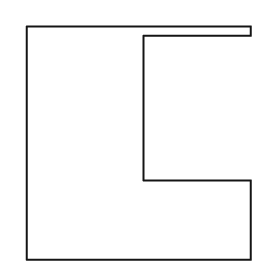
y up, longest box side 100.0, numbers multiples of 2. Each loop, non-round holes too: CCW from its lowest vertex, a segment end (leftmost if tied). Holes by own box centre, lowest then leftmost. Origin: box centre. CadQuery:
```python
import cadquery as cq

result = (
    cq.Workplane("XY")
    .moveTo(-48.0, -50.0)
    .lineTo(48.0, -50.0)
    .lineTo(48.0, -16.0)
    .lineTo(2.0, -16.0)
    .lineTo(2.0, 46.0)
    .lineTo(48.0, 46.0)
    .lineTo(48.0, 50.0)
    .lineTo(-48.0, 50.0)
    .close()
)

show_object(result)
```